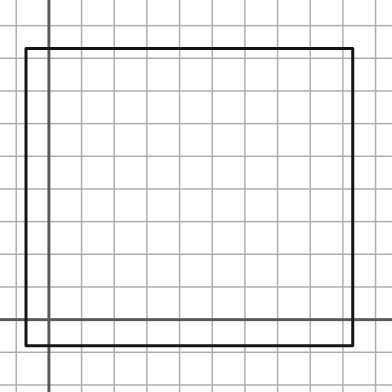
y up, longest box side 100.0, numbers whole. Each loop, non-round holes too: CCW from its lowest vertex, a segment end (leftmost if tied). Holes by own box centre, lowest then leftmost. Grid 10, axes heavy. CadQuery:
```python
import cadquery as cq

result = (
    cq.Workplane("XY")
    .moveTo(-7.0, -8.0)
    .lineTo(93.0, -8.0)
    .lineTo(93.0, 83.0)
    .lineTo(-7.0, 83.0)
    .close()
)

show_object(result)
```